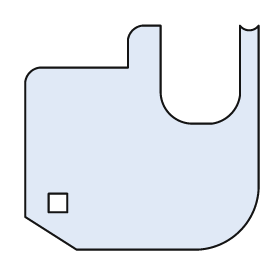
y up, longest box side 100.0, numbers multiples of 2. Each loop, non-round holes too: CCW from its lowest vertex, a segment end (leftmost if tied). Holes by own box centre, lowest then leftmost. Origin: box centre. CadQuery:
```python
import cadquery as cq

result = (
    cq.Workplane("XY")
    .moveTo(-28.0, -48.0)
    .lineTo(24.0, -48.0)
    .threePointArc((42.0, -40.0), (50.0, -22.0))
    .lineTo(50.0, 48.0)
    .threePointArc((46.0, 46.0), (42.0, 48.0))
    .lineTo(42.0, 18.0)
    .threePointArc((38.0, 10.0), (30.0, 6.0))
    .lineTo(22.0, 6.0)
    .threePointArc((12.0, 10.0), (8.0, 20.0))
    .lineTo(8.0, 48.0)
    .lineTo(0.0, 48.0)
    .threePointArc((-4.0, 46.0), (-6.0, 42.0))
    .lineTo(-6.0, 30.0)
    .lineTo(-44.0, 30.0)
    .threePointArc((-48.0, 28.0), (-50.0, 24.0))
    .lineTo(-50.0, -34.0)
    .close()
    .moveTo(-40.0, -32.0)
    .lineTo(-32.0, -32.0)
    .lineTo(-32.0, -24.0)
    .lineTo(-40.0, -24.0)
    .close()
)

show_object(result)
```